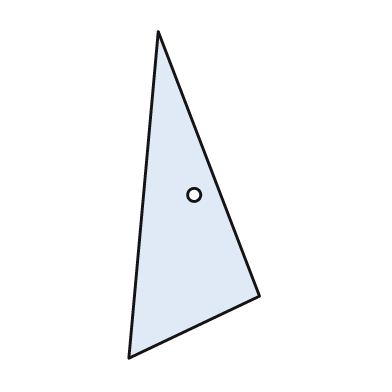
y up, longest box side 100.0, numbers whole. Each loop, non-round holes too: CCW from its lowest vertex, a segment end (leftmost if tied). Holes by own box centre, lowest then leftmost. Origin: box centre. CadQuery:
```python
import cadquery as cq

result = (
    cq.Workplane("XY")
    .moveTo(-20.0, -50.0)
    .lineTo(20.0, -31.0)
    .lineTo(-11.0, 50.0)
    .close()
    .moveTo(0.0, 0.0)
    .circle(2.0)
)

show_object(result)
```